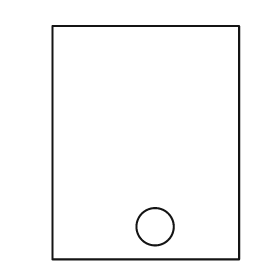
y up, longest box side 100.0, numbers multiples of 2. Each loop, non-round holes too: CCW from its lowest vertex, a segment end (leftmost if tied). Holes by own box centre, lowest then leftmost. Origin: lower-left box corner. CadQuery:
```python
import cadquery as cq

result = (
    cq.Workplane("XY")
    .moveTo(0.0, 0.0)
    .lineTo(80.0, 0.0)
    .lineTo(80.0, 100.0)
    .lineTo(0.0, 100.0)
    .close()
    .moveTo(44.0, 14.0)
    .circle(8.0)
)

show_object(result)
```